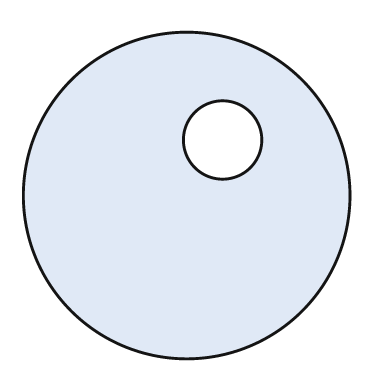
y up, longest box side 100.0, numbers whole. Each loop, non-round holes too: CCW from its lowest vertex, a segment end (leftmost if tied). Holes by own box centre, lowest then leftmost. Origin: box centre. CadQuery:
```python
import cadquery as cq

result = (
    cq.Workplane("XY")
    .moveTo(0.0, 0.0)
    .circle(50.0)
    .moveTo(11.0, 17.0)
    .circle(12.0)
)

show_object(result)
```